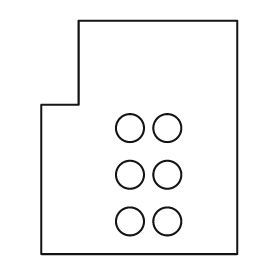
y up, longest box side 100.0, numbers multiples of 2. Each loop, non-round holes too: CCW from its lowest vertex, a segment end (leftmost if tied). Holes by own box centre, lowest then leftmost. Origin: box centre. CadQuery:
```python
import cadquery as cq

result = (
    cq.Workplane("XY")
    .moveTo(-42.0, -50.0)
    .lineTo(42.0, -50.0)
    .lineTo(42.0, 50.0)
    .lineTo(-26.0, 50.0)
    .lineTo(-26.0, 14.0)
    .lineTo(-42.0, 14.0)
    .close()
    .moveTo(-4.0, -36.0)
    .circle(6.0)
    .moveTo(12.0, -36.0)
    .circle(6.0)
    .moveTo(-4.0, -16.0)
    .circle(6.0)
    .moveTo(12.0, -16.0)
    .circle(6.0)
    .moveTo(-4.0, 4.0)
    .circle(6.0)
    .moveTo(12.0, 4.0)
    .circle(6.0)
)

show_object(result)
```